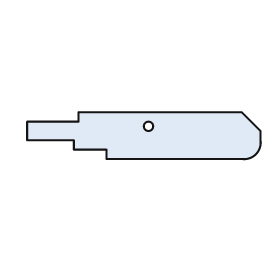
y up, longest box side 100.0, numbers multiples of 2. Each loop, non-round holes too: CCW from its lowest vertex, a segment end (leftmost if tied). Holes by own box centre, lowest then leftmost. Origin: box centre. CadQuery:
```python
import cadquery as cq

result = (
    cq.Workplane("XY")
    .moveTo(-16.0, -10.0)
    .lineTo(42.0, -10.0)
    .threePointArc((48.0, -8.0), (50.0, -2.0))
    .lineTo(50.0, 2.0)
    .lineTo(42.0, 10.0)
    .lineTo(-28.0, 10.0)
    .lineTo(-28.0, 6.0)
    .lineTo(-50.0, 6.0)
    .lineTo(-50.0, -2.0)
    .lineTo(-30.0, -2.0)
    .lineTo(-30.0, -6.0)
    .lineTo(-16.0, -6.0)
    .close()
    .moveTo(2.0, 4.0)
    .circle(2.0)
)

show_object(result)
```